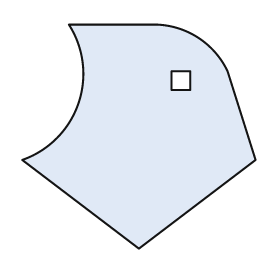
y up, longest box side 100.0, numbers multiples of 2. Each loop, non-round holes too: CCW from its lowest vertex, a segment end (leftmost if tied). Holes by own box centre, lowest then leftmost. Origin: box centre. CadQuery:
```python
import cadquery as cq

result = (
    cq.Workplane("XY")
    .moveTo(0.0, -48.0)
    .lineTo(50.0, -10.0)
    .lineTo(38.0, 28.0)
    .threePointArc((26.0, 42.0), (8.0, 48.0))
    .lineTo(-30.0, 48.0)
    .threePointArc((-26.0, 14.0), (-50.0, -10.0))
    .close()
    .moveTo(14.0, 20.0)
    .lineTo(22.0, 20.0)
    .lineTo(22.0, 28.0)
    .lineTo(14.0, 28.0)
    .close()
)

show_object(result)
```